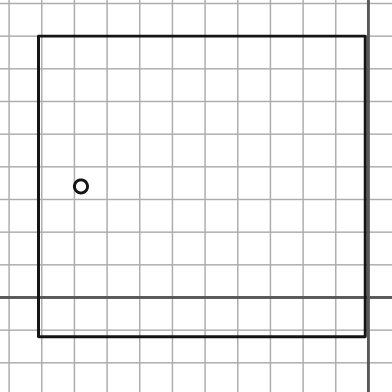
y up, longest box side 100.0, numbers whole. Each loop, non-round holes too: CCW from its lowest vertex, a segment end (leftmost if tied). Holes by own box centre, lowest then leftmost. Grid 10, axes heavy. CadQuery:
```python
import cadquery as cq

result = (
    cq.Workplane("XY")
    .moveTo(-101.0, -12.0)
    .lineTo(-1.0, -12.0)
    .lineTo(-1.0, 80.0)
    .lineTo(-101.0, 80.0)
    .close()
    .moveTo(-88.0, 34.0)
    .circle(2.0)
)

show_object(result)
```